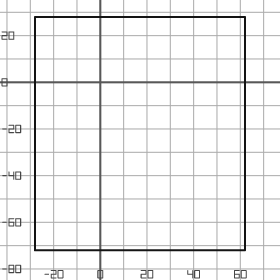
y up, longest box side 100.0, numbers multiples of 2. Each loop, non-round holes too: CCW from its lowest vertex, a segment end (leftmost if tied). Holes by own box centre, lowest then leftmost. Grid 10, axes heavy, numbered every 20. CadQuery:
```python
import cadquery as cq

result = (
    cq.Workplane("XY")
    .moveTo(-28.0, -72.0)
    .lineTo(62.0, -72.0)
    .lineTo(62.0, 28.0)
    .lineTo(-28.0, 28.0)
    .close()
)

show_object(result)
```